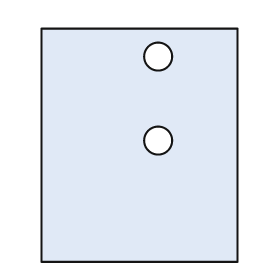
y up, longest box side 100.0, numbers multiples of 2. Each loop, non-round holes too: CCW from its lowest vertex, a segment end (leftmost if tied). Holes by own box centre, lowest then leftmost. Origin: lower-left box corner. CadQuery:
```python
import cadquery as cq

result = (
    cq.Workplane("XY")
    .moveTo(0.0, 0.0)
    .lineTo(84.0, 0.0)
    .lineTo(84.0, 100.0)
    .lineTo(0.0, 100.0)
    .close()
    .moveTo(50.0, 52.0)
    .circle(6.0)
    .moveTo(50.0, 88.0)
    .circle(6.0)
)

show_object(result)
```